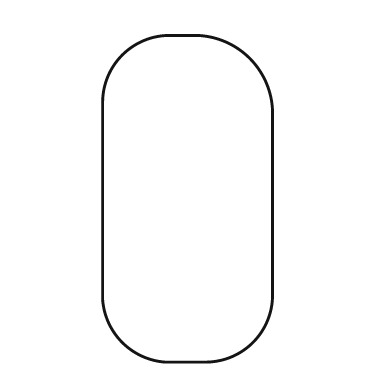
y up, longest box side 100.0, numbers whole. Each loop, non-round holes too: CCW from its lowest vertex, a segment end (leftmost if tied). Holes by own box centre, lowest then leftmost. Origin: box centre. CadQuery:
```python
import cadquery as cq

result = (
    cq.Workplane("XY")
    .moveTo(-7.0, -50.0)
    .lineTo(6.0, -50.0)
    .threePointArc((20.0, -44.0), (26.0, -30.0))
    .lineTo(26.0, 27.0)
    .threePointArc((19.0, 43.0), (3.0, 50.0))
    .lineTo(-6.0, 50.0)
    .threePointArc((-20.0, 44.0), (-26.0, 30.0))
    .lineTo(-26.0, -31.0)
    .threePointArc((-20.0, -44.0), (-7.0, -50.0))
    .close()
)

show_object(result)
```